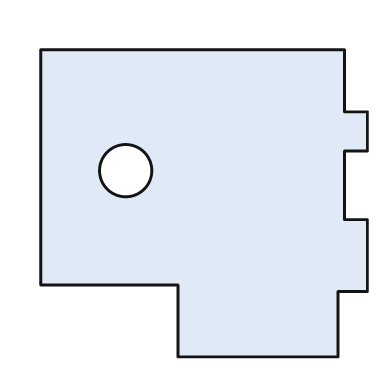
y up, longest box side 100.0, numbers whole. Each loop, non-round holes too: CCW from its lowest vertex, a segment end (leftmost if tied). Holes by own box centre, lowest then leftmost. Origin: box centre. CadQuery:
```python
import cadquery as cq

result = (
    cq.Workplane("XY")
    .moveTo(-8.0, -47.0)
    .lineTo(41.0, -47.0)
    .lineTo(41.0, -27.0)
    .lineTo(50.0, -27.0)
    .lineTo(50.0, -5.0)
    .lineTo(43.0, -5.0)
    .lineTo(43.0, 16.0)
    .lineTo(50.0, 16.0)
    .lineTo(50.0, 28.0)
    .lineTo(43.0, 28.0)
    .lineTo(43.0, 47.0)
    .lineTo(-50.0, 47.0)
    .lineTo(-50.0, -25.0)
    .lineTo(-8.0, -25.0)
    .close()
    .moveTo(-24.0, 10.0)
    .circle(8.0)
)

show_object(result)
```